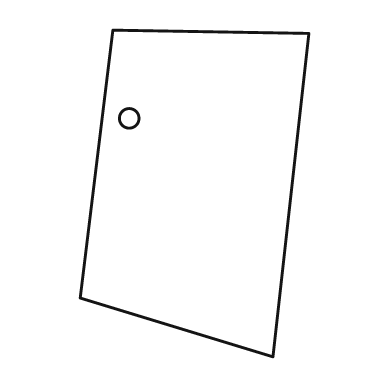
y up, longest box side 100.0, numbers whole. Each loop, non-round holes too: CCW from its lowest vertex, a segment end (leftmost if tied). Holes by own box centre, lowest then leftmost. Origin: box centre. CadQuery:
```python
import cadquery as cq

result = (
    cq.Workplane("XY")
    .moveTo(24.0, -50.0)
    .lineTo(35.0, 49.0)
    .lineTo(-25.0, 50.0)
    .lineTo(-35.0, -32.0)
    .close()
    .moveTo(-20.0, 23.0)
    .circle(3.0)
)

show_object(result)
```